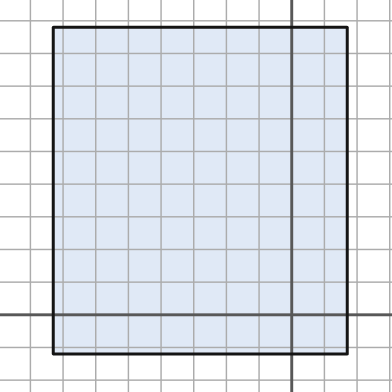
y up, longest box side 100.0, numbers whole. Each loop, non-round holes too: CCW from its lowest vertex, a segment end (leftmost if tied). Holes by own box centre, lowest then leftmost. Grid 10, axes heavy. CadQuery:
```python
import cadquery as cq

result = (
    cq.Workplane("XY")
    .moveTo(-73.0, -12.0)
    .lineTo(17.0, -12.0)
    .lineTo(17.0, 88.0)
    .lineTo(-73.0, 88.0)
    .close()
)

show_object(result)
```